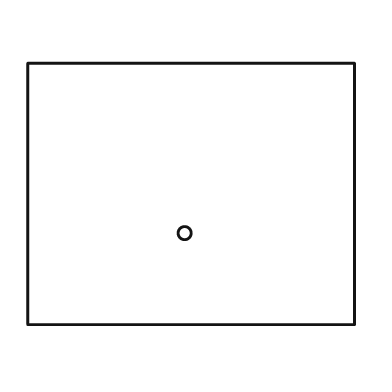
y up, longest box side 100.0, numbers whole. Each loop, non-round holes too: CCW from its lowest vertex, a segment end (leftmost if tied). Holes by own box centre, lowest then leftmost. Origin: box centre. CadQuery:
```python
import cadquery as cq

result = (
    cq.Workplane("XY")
    .moveTo(-50.0, -40.0)
    .lineTo(50.0, -40.0)
    .lineTo(50.0, 40.0)
    .lineTo(-50.0, 40.0)
    .close()
    .moveTo(-2.0, -12.0)
    .circle(2.0)
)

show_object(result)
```